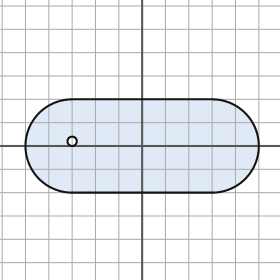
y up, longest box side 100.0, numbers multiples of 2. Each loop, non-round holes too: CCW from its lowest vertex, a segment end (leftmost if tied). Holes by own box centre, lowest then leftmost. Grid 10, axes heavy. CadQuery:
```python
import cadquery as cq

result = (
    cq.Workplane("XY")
    .moveTo(-30.0, -20.0)
    .lineTo(30.0, -20.0)
    .threePointArc((50.0, 0.0), (30.0, 20.0))
    .lineTo(-30.0, 20.0)
    .threePointArc((-50.0, 0.0), (-30.0, -20.0))
    .close()
    .moveTo(-30.0, 2.0)
    .circle(2.0)
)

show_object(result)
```